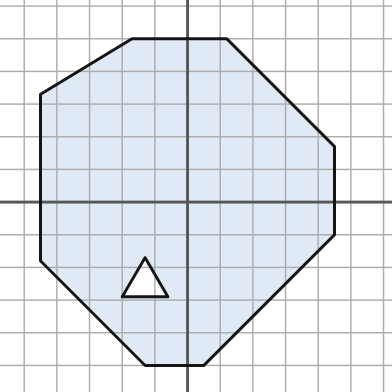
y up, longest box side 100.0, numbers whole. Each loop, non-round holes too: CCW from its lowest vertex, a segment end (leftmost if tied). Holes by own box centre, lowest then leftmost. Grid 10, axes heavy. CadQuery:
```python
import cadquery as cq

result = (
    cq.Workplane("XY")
    .moveTo(-13.0, -50.0)
    .lineTo(5.0, -50.0)
    .lineTo(45.0, -10.0)
    .lineTo(45.0, 17.0)
    .lineTo(12.0, 50.0)
    .lineTo(-17.0, 50.0)
    .lineTo(-45.0, 33.0)
    .lineTo(-45.0, -18.0)
    .close()
    .moveTo(-20.0, -29.0)
    .lineTo(-6.0, -29.0)
    .lineTo(-13.0, -17.0)
    .close()
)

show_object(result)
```